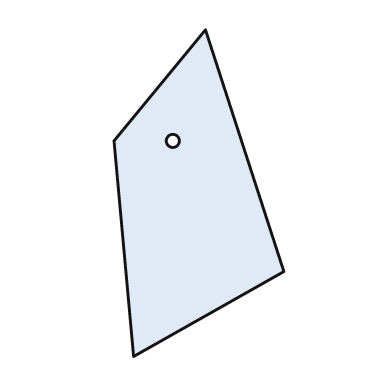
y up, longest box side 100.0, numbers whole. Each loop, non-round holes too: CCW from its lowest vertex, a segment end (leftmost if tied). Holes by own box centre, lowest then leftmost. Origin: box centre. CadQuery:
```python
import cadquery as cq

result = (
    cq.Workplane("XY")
    .moveTo(-20.0, -50.0)
    .lineTo(26.0, -24.0)
    .lineTo(2.0, 50.0)
    .lineTo(-26.0, 16.0)
    .close()
    .moveTo(-8.0, 16.0)
    .circle(2.0)
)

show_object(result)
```